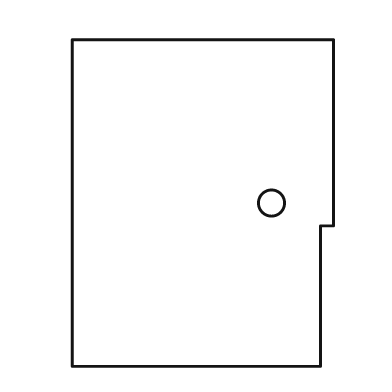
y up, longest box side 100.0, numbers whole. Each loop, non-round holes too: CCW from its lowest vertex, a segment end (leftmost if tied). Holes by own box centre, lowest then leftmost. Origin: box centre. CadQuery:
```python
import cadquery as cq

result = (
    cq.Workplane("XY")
    .moveTo(-40.0, -50.0)
    .lineTo(36.0, -50.0)
    .lineTo(36.0, -7.0)
    .lineTo(40.0, -7.0)
    .lineTo(40.0, 50.0)
    .lineTo(-40.0, 50.0)
    .close()
    .moveTo(21.0, 0.0)
    .circle(4.0)
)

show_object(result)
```